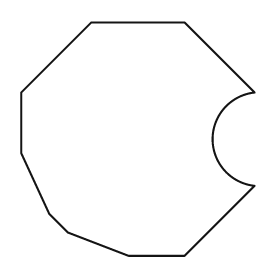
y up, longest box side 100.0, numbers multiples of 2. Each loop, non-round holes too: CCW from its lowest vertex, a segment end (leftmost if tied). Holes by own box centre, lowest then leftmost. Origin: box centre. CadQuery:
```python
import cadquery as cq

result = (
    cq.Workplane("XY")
    .moveTo(-4.0, -50.0)
    .lineTo(20.0, -50.0)
    .lineTo(50.0, -20.0)
    .threePointArc((32.0, 0.0), (50.0, 20.0))
    .lineTo(20.0, 50.0)
    .lineTo(-20.0, 50.0)
    .lineTo(-50.0, 20.0)
    .lineTo(-50.0, -6.0)
    .lineTo(-38.0, -32.0)
    .lineTo(-30.0, -40.0)
    .close()
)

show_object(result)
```